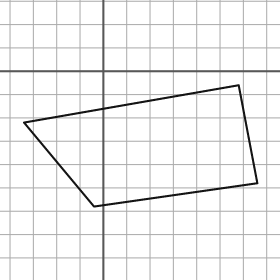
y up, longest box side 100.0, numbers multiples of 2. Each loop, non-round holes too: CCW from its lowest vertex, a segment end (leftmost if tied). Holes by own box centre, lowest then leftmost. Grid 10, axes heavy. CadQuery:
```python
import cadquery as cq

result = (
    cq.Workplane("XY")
    .moveTo(-4.0, -58.0)
    .lineTo(66.0, -48.0)
    .lineTo(58.0, -6.0)
    .lineTo(-34.0, -22.0)
    .close()
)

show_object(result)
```